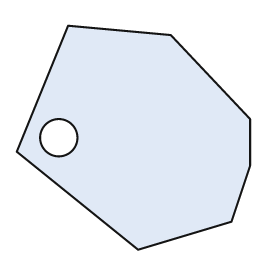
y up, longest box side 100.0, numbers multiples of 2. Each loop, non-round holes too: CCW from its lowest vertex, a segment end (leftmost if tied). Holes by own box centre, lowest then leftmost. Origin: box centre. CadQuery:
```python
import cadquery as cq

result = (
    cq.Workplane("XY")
    .moveTo(2.0, -48.0)
    .lineTo(42.0, -36.0)
    .lineTo(50.0, -12.0)
    .lineTo(50.0, 8.0)
    .lineTo(16.0, 44.0)
    .lineTo(-28.0, 48.0)
    .lineTo(-50.0, -6.0)
    .close()
    .moveTo(-32.0, 0.0)
    .circle(8.0)
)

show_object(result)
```